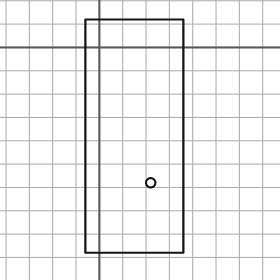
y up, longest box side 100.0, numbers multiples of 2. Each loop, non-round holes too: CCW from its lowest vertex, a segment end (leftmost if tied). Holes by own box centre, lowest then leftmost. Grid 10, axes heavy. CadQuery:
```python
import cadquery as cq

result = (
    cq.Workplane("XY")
    .moveTo(-6.0, -88.0)
    .lineTo(36.0, -88.0)
    .lineTo(36.0, 12.0)
    .lineTo(-6.0, 12.0)
    .close()
    .moveTo(22.0, -58.0)
    .circle(2.0)
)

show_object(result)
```